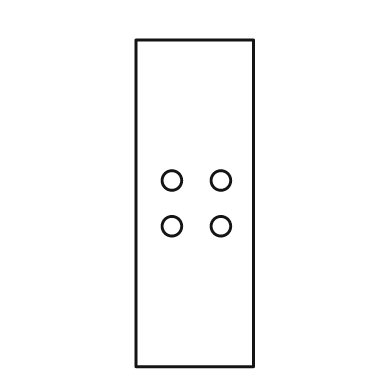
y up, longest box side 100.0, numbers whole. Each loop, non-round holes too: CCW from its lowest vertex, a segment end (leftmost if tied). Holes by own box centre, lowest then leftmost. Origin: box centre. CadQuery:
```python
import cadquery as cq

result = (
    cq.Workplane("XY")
    .moveTo(-18.0, -50.0)
    .lineTo(18.0, -50.0)
    .lineTo(18.0, 50.0)
    .lineTo(-18.0, 50.0)
    .close()
    .moveTo(-7.0, -7.0)
    .circle(3.0)
    .moveTo(8.0, -7.0)
    .circle(3.0)
    .moveTo(-7.0, 7.0)
    .circle(3.0)
    .moveTo(8.0, 7.0)
    .circle(3.0)
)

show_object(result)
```